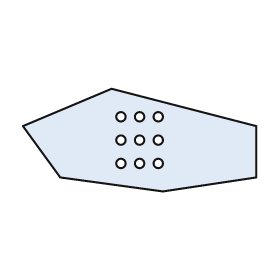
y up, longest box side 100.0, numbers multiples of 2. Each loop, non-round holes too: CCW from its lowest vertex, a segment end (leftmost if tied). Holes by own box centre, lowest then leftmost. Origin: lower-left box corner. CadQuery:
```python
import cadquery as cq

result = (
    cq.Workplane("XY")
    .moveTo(60.0, 0.0)
    .lineTo(100.0, 6.0)
    .lineTo(100.0, 28.0)
    .lineTo(38.0, 44.0)
    .lineTo(0.0, 28.0)
    .lineTo(16.0, 6.0)
    .close()
    .moveTo(42.0, 12.0)
    .circle(2.0)
    .moveTo(50.0, 12.0)
    .circle(2.0)
    .moveTo(58.0, 12.0)
    .circle(2.0)
    .moveTo(42.0, 22.0)
    .circle(2.0)
    .moveTo(50.0, 22.0)
    .circle(2.0)
    .moveTo(58.0, 22.0)
    .circle(2.0)
    .moveTo(42.0, 32.0)
    .circle(2.0)
    .moveTo(50.0, 32.0)
    .circle(2.0)
    .moveTo(58.0, 32.0)
    .circle(2.0)
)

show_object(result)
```